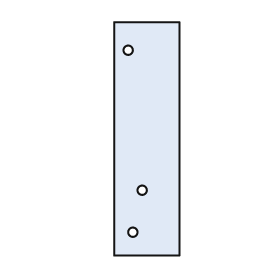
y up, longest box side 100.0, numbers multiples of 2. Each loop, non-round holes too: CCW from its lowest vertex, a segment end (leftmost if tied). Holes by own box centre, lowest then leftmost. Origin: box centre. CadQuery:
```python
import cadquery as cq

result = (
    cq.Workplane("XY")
    .moveTo(-14.0, -50.0)
    .lineTo(14.0, -50.0)
    .lineTo(14.0, 50.0)
    .lineTo(-14.0, 50.0)
    .close()
    .moveTo(-6.0, -40.0)
    .circle(2.0)
    .moveTo(-2.0, -22.0)
    .circle(2.0)
    .moveTo(-8.0, 38.0)
    .circle(2.0)
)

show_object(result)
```